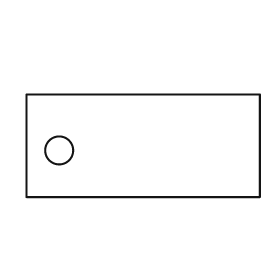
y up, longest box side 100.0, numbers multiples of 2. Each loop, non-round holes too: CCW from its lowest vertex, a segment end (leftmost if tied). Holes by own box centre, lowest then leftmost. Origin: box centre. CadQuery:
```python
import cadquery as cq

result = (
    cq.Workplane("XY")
    .moveTo(-50.0, -22.0)
    .lineTo(50.0, -22.0)
    .lineTo(50.0, 22.0)
    .lineTo(-50.0, 22.0)
    .close()
    .moveTo(-36.0, -2.0)
    .circle(6.0)
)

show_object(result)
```